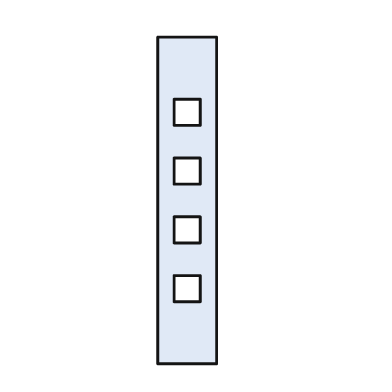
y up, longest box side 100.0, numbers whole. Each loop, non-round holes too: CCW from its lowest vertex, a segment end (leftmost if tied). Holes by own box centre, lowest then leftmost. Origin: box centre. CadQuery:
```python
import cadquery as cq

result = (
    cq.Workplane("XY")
    .moveTo(-9.0, -50.0)
    .lineTo(9.0, -50.0)
    .lineTo(9.0, 50.0)
    .lineTo(-9.0, 50.0)
    .close()
    .moveTo(-4.0, -31.0)
    .lineTo(4.0, -31.0)
    .lineTo(4.0, -23.0)
    .lineTo(-4.0, -23.0)
    .close()
    .moveTo(-4.0, -13.0)
    .lineTo(4.0, -13.0)
    .lineTo(4.0, -5.0)
    .lineTo(-4.0, -5.0)
    .close()
    .moveTo(-4.0, 5.0)
    .lineTo(4.0, 5.0)
    .lineTo(4.0, 13.0)
    .lineTo(-4.0, 13.0)
    .close()
    .moveTo(-4.0, 23.0)
    .lineTo(4.0, 23.0)
    .lineTo(4.0, 31.0)
    .lineTo(-4.0, 31.0)
    .close()
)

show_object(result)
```